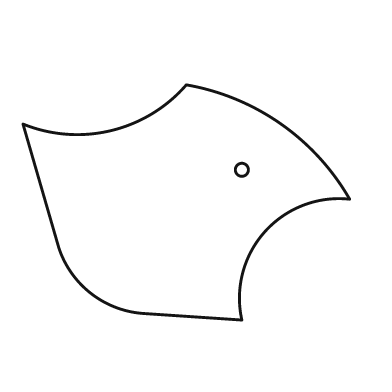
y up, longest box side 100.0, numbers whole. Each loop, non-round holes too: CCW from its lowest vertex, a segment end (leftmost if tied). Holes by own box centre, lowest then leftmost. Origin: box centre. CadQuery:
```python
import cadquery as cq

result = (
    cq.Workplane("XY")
    .moveTo(17.0, -36.0)
    .threePointArc((24.0, -9.0), (50.0, 1.0))
    .threePointArc((29.0, 24.0), (0.0, 36.0))
    .threePointArc((-23.0, 22.0), (-50.0, 24.0))
    .lineTo(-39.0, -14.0)
    .threePointArc((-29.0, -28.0), (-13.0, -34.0))
    .close()
    .moveTo(17.0, 10.0)
    .circle(2.0)
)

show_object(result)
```